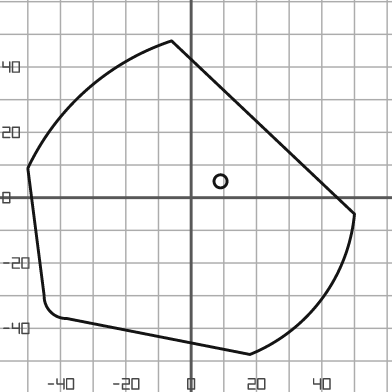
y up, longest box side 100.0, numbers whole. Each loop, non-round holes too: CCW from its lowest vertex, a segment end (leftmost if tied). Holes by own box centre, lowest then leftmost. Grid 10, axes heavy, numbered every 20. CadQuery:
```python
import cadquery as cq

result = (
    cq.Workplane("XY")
    .moveTo(18.0, -48.0)
    .threePointArc((40.0, -31.0), (50.0, -5.0))
    .lineTo(-6.0, 48.0)
    .threePointArc((-32.0, 33.0), (-50.0, 9.0))
    .lineTo(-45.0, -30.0)
    .threePointArc((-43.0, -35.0), (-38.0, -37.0))
    .close()
    .moveTo(9.0, 5.0)
    .circle(2.0)
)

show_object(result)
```